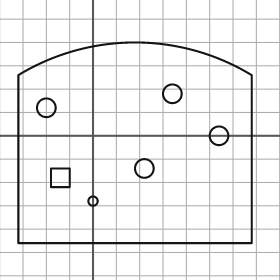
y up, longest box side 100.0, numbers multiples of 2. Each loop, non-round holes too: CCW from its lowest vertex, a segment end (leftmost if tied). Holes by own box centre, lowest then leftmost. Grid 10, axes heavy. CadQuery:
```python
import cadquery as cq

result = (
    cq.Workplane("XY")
    .moveTo(-32.0, -46.0)
    .lineTo(68.0, -46.0)
    .lineTo(68.0, 26.0)
    .threePointArc((18.0, 40.0), (-32.0, 26.0))
    .close()
    .moveTo(0.0, -28.0)
    .circle(2.0)
    .moveTo(-18.0, -22.0)
    .lineTo(-10.0, -22.0)
    .lineTo(-10.0, -14.0)
    .lineTo(-18.0, -14.0)
    .close()
    .moveTo(22.0, -14.0)
    .circle(4.0)
    .moveTo(54.0, 0.0)
    .circle(4.0)
    .moveTo(-20.0, 12.0)
    .circle(4.0)
    .moveTo(34.0, 18.0)
    .circle(4.0)
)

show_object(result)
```